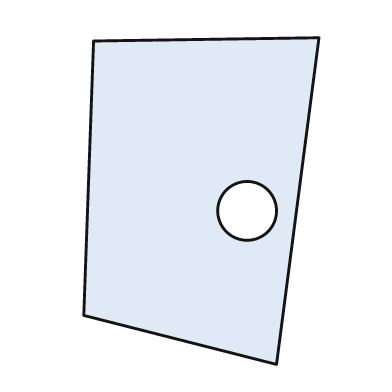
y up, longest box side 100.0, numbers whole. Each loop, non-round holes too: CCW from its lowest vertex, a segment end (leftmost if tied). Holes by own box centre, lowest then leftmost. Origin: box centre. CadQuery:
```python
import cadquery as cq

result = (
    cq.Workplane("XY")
    .moveTo(23.0, -50.0)
    .lineTo(36.0, 50.0)
    .lineTo(-33.0, 49.0)
    .lineTo(-36.0, -35.0)
    .close()
    .moveTo(14.0, -3.0)
    .circle(9.0)
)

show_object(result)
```